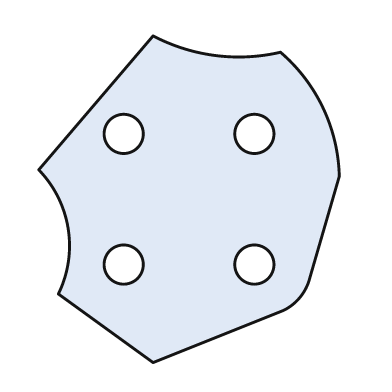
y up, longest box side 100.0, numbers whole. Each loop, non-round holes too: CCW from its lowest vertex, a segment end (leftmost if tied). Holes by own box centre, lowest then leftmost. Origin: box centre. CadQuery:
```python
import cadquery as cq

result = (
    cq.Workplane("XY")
    .moveTo(-11.0, -50.0)
    .lineTo(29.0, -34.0)
    .threePointArc((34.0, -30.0), (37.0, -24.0))
    .lineTo(46.0, 7.0)
    .threePointArc((41.0, 28.0), (28.0, 45.0))
    .threePointArc((8.0, 44.0), (-11.0, 50.0))
    .lineTo(-46.0, 9.0)
    .threePointArc((-37.0, -9.0), (-40.0, -29.0))
    .close()
    .moveTo(-20.0, -20.0)
    .circle(6.0)
    .moveTo(20.0, -20.0)
    .circle(6.0)
    .moveTo(-20.0, 20.0)
    .circle(6.0)
    .moveTo(20.0, 20.0)
    .circle(6.0)
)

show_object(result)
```